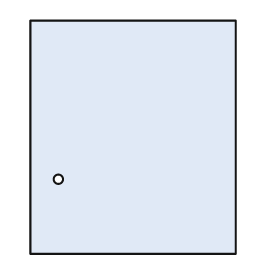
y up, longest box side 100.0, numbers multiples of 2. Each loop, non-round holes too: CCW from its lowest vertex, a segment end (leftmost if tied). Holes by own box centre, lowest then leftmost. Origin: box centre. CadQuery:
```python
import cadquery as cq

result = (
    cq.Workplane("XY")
    .moveTo(-44.0, -50.0)
    .lineTo(44.0, -50.0)
    .lineTo(44.0, 50.0)
    .lineTo(-44.0, 50.0)
    .close()
    .moveTo(-32.0, -18.0)
    .circle(2.0)
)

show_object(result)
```